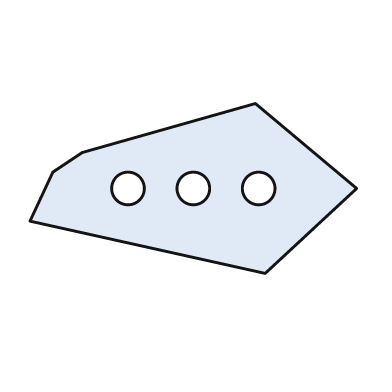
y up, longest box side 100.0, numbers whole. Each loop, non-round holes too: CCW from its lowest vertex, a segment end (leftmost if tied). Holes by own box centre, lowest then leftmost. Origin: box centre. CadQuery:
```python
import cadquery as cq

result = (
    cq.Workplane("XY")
    .moveTo(22.0, -26.0)
    .lineTo(50.0, 0.0)
    .lineTo(19.0, 26.0)
    .lineTo(-34.0, 11.0)
    .lineTo(-43.0, 5.0)
    .lineTo(-50.0, -10.0)
    .close()
    .moveTo(-20.0, 0.0)
    .circle(5.0)
    .moveTo(0.0, 0.0)
    .circle(5.0)
    .moveTo(20.0, 0.0)
    .circle(5.0)
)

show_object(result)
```